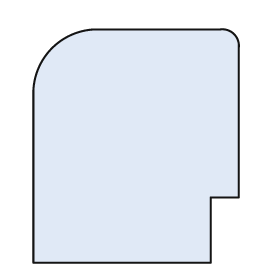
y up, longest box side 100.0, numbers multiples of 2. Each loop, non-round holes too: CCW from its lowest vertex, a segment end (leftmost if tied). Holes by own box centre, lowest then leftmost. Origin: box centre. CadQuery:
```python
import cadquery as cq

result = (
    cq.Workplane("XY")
    .moveTo(-44.0, -50.0)
    .lineTo(32.0, -50.0)
    .lineTo(32.0, -22.0)
    .lineTo(44.0, -22.0)
    .lineTo(44.0, 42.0)
    .threePointArc((42.0, 48.0), (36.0, 50.0))
    .lineTo(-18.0, 50.0)
    .threePointArc((-36.0, 42.0), (-44.0, 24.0))
    .close()
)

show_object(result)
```